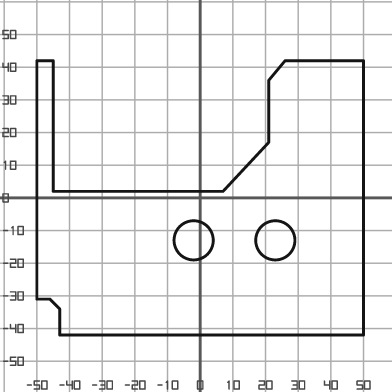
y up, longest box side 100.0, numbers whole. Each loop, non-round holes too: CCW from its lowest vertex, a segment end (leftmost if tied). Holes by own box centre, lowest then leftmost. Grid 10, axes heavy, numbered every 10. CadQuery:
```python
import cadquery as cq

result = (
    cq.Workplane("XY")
    .moveTo(-43.0, -42.0)
    .lineTo(50.0, -42.0)
    .lineTo(50.0, 42.0)
    .lineTo(26.0, 42.0)
    .lineTo(21.0, 36.0)
    .lineTo(21.0, 17.0)
    .lineTo(7.0, 2.0)
    .lineTo(-45.0, 2.0)
    .lineTo(-45.0, 42.0)
    .lineTo(-50.0, 42.0)
    .lineTo(-50.0, -31.0)
    .lineTo(-46.0, -31.0)
    .lineTo(-43.0, -34.0)
    .close()
    .moveTo(-2.0, -13.0)
    .circle(6.0)
    .moveTo(23.0, -13.0)
    .circle(6.0)
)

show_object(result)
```